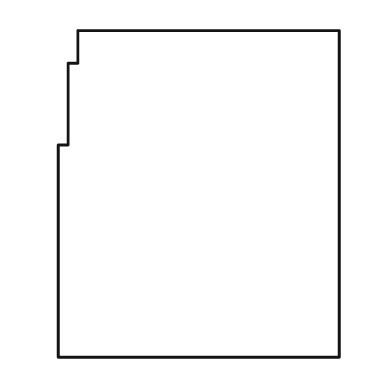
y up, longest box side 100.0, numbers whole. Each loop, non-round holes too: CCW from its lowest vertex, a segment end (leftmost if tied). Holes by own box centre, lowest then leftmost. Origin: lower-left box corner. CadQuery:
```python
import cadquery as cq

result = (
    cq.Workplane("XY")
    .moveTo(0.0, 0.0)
    .lineTo(86.0, 0.0)
    .lineTo(86.0, 100.0)
    .lineTo(6.0, 100.0)
    .lineTo(6.0, 90.0)
    .lineTo(3.0, 90.0)
    .lineTo(3.0, 65.0)
    .lineTo(0.0, 65.0)
    .close()
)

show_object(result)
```